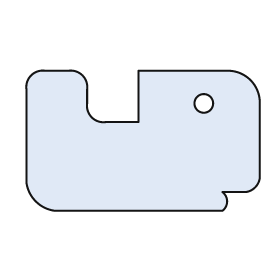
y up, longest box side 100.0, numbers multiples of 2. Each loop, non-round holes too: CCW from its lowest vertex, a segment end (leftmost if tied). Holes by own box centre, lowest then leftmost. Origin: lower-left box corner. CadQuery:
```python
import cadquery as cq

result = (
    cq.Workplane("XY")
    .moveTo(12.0, 0.0)
    .lineTo(84.0, 0.0)
    .threePointArc((86.0, 4.0), (84.0, 8.0))
    .lineTo(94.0, 8.0)
    .threePointArc((98.0, 10.0), (100.0, 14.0))
    .lineTo(100.0, 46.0)
    .threePointArc((96.0, 56.0), (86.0, 60.0))
    .lineTo(48.0, 60.0)
    .lineTo(48.0, 38.0)
    .lineTo(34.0, 38.0)
    .threePointArc((28.0, 40.0), (26.0, 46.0))
    .lineTo(26.0, 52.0)
    .threePointArc((24.0, 58.0), (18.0, 60.0))
    .lineTo(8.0, 60.0)
    .threePointArc((2.0, 58.0), (0.0, 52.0))
    .lineTo(0.0, 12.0)
    .threePointArc((4.0, 4.0), (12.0, 0.0))
    .close()
    .moveTo(76.0, 46.0)
    .circle(4.0)
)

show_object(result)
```